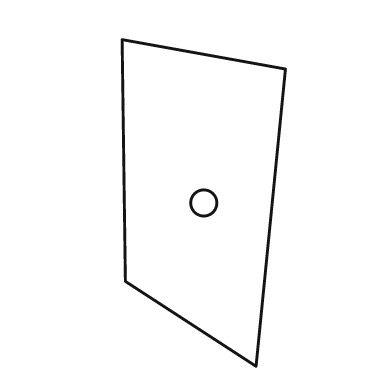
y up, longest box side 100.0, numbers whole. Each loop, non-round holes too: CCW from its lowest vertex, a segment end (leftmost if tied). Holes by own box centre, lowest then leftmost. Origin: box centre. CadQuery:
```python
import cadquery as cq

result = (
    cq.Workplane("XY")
    .moveTo(16.0, -50.0)
    .lineTo(25.0, 41.0)
    .lineTo(-25.0, 50.0)
    .lineTo(-24.0, -24.0)
    .close()
    .moveTo(0.0, 0.0)
    .circle(4.0)
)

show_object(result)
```